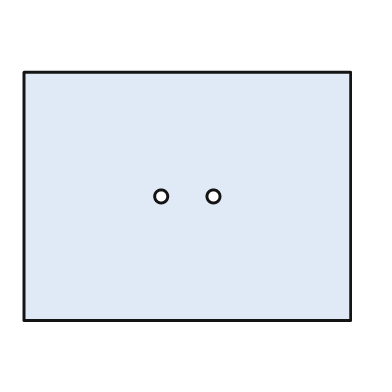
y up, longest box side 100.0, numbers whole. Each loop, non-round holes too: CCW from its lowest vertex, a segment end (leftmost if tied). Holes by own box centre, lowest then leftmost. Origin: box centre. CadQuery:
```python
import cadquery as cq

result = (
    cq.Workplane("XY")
    .moveTo(-50.0, -38.0)
    .lineTo(50.0, -38.0)
    .lineTo(50.0, 38.0)
    .lineTo(-50.0, 38.0)
    .close()
    .moveTo(-8.0, 0.0)
    .circle(2.0)
    .moveTo(8.0, 0.0)
    .circle(2.0)
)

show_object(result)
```